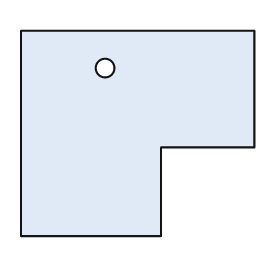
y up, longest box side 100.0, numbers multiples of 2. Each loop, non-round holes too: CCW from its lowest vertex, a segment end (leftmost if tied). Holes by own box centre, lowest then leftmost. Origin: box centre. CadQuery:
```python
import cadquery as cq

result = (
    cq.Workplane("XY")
    .moveTo(-50.0, -44.0)
    .lineTo(10.0, -44.0)
    .lineTo(10.0, -6.0)
    .lineTo(50.0, -6.0)
    .lineTo(50.0, 44.0)
    .lineTo(-50.0, 44.0)
    .close()
    .moveTo(-14.0, 28.0)
    .circle(4.0)
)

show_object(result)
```